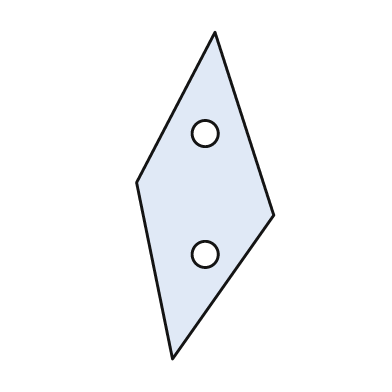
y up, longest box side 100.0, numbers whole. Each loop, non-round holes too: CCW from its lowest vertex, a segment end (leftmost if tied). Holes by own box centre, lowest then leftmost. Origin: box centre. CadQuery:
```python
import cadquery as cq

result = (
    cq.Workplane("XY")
    .moveTo(-10.0, -50.0)
    .lineTo(21.0, -6.0)
    .lineTo(3.0, 50.0)
    .lineTo(-21.0, 4.0)
    .close()
    .moveTo(0.0, -18.0)
    .circle(4.0)
    .moveTo(0.0, 19.0)
    .circle(4.0)
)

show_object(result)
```